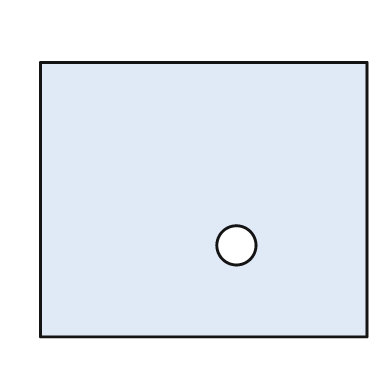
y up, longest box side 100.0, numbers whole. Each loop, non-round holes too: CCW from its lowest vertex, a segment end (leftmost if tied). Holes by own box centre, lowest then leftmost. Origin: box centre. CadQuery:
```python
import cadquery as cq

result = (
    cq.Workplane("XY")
    .moveTo(-50.0, -42.0)
    .lineTo(50.0, -42.0)
    .lineTo(50.0, 42.0)
    .lineTo(-50.0, 42.0)
    .close()
    .moveTo(10.0, -14.0)
    .circle(6.0)
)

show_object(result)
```